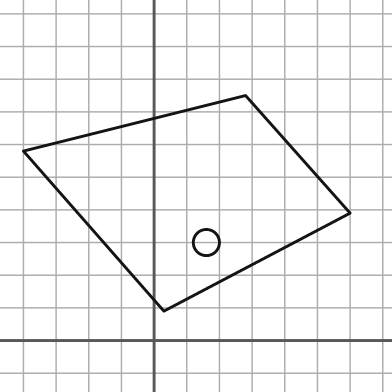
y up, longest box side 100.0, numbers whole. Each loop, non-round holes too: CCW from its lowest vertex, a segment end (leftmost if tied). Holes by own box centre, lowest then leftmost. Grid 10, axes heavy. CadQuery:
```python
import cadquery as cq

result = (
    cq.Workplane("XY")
    .moveTo(3.0, 9.0)
    .lineTo(60.0, 39.0)
    .lineTo(28.0, 75.0)
    .lineTo(-40.0, 58.0)
    .close()
    .moveTo(16.0, 30.0)
    .circle(4.0)
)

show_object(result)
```